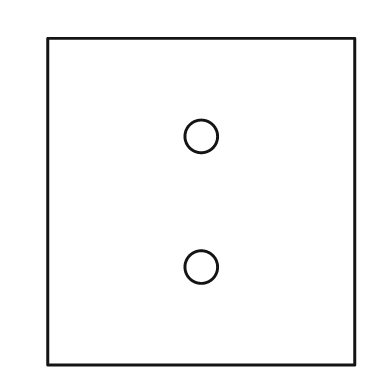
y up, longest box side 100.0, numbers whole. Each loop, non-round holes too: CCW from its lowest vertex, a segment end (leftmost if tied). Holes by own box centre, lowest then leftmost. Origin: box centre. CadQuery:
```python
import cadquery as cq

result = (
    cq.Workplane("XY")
    .moveTo(-47.0, -50.0)
    .lineTo(47.0, -50.0)
    .lineTo(47.0, 50.0)
    .lineTo(-47.0, 50.0)
    .close()
    .moveTo(0.0, -20.0)
    .circle(5.0)
    .moveTo(0.0, 20.0)
    .circle(5.0)
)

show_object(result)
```